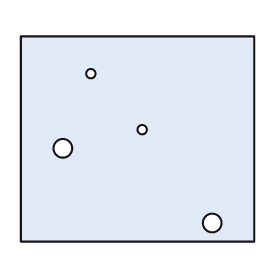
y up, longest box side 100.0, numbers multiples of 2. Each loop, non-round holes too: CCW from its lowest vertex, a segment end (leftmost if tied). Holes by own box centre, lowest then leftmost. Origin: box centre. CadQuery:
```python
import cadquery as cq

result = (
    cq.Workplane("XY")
    .moveTo(-50.0, -44.0)
    .lineTo(50.0, -44.0)
    .lineTo(50.0, 44.0)
    .lineTo(-50.0, 44.0)
    .close()
    .moveTo(32.0, -36.0)
    .circle(4.0)
    .moveTo(-32.0, -4.0)
    .circle(4.0)
    .moveTo(2.0, 4.0)
    .circle(2.0)
    .moveTo(-20.0, 28.0)
    .circle(2.0)
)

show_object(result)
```